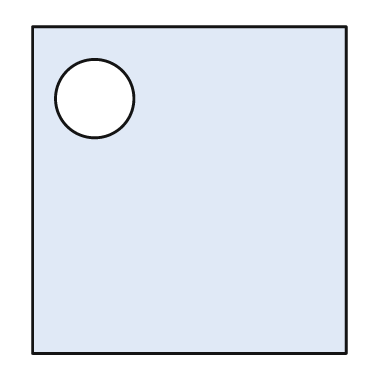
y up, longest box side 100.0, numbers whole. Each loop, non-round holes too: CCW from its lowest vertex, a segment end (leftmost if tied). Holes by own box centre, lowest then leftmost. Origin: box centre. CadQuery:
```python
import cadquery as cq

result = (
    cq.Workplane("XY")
    .moveTo(-48.0, -50.0)
    .lineTo(48.0, -50.0)
    .lineTo(48.0, 50.0)
    .lineTo(-48.0, 50.0)
    .close()
    .moveTo(-29.0, 28.0)
    .circle(12.0)
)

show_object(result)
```